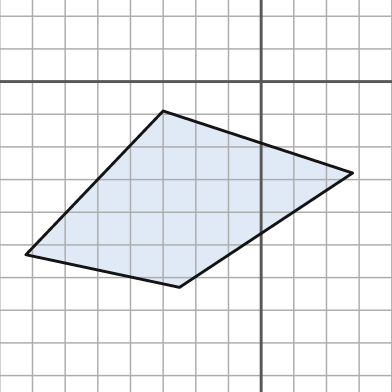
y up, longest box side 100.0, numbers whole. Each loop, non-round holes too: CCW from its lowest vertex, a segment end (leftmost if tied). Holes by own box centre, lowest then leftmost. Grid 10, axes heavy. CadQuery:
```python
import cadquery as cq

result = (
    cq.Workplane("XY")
    .moveTo(-25.0, -63.0)
    .lineTo(28.0, -28.0)
    .lineTo(-30.0, -9.0)
    .lineTo(-72.0, -53.0)
    .close()
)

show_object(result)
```